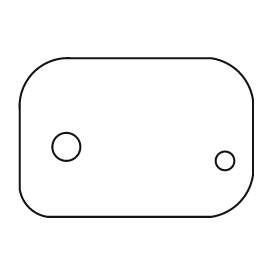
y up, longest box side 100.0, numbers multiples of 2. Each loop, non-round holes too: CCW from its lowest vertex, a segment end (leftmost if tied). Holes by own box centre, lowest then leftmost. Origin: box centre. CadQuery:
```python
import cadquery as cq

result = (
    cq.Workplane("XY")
    .moveTo(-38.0, -34.0)
    .lineTo(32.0, -34.0)
    .threePointArc((44.0, -28.0), (50.0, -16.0))
    .lineTo(50.0, 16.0)
    .threePointArc((44.0, 28.0), (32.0, 34.0))
    .lineTo(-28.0, 34.0)
    .threePointArc((-44.0, 28.0), (-50.0, 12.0))
    .lineTo(-50.0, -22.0)
    .threePointArc((-46.0, -30.0), (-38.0, -34.0))
    .close()
    .moveTo(38.0, -10.0)
    .circle(4.0)
    .moveTo(-30.0, -4.0)
    .circle(6.0)
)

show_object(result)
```